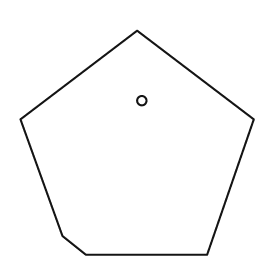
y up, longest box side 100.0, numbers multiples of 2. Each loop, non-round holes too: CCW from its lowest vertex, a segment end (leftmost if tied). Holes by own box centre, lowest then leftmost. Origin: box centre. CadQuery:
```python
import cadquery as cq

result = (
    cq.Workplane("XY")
    .moveTo(-22.0, -48.0)
    .lineTo(30.0, -48.0)
    .lineTo(50.0, 10.0)
    .lineTo(0.0, 48.0)
    .lineTo(-50.0, 10.0)
    .lineTo(-32.0, -40.0)
    .close()
    .moveTo(2.0, 18.0)
    .circle(2.0)
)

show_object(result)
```